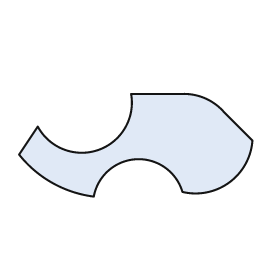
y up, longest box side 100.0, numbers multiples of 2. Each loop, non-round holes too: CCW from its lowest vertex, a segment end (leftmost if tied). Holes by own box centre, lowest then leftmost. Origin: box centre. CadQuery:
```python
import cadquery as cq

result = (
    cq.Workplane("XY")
    .moveTo(-18.0, -22.0)
    .threePointArc((0.0, -6.0), (20.0, -20.0))
    .threePointArc((40.0, -16.0), (50.0, 2.0))
    .lineTo(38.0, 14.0)
    .threePointArc((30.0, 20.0), (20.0, 22.0))
    .lineTo(-2.0, 22.0)
    .threePointArc((-16.0, -2.0), (-42.0, 8.0))
    .lineTo(-50.0, -4.0)
    .threePointArc((-36.0, -16.0), (-18.0, -22.0))
    .close()
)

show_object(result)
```